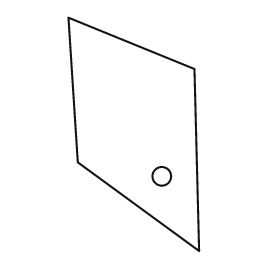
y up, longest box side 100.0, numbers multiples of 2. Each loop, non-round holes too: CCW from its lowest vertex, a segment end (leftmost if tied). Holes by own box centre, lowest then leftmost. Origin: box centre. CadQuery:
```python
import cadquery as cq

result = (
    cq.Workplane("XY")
    .moveTo(28.0, -50.0)
    .lineTo(26.0, 28.0)
    .lineTo(-28.0, 50.0)
    .lineTo(-24.0, -12.0)
    .close()
    .moveTo(12.0, -18.0)
    .circle(4.0)
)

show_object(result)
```